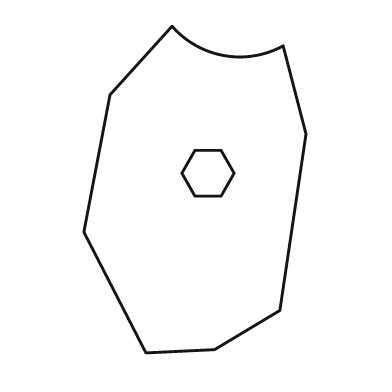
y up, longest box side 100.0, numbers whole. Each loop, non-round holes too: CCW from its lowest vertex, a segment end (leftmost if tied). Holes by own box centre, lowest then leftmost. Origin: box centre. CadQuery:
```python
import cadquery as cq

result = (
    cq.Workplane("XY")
    .moveTo(-15.0, -50.0)
    .lineTo(6.0, -49.0)
    .lineTo(26.0, -37.0)
    .lineTo(34.0, 17.0)
    .lineTo(27.0, 44.0)
    .threePointArc((9.0, 41.0), (-7.0, 50.0))
    .lineTo(-26.0, 29.0)
    .lineTo(-34.0, -13.0)
    .close()
    .moveTo(0.0, -2.0)
    .lineTo(8.0, -2.0)
    .lineTo(12.0, 5.0)
    .lineTo(8.0, 12.0)
    .lineTo(0.0, 12.0)
    .lineTo(-4.0, 5.0)
    .close()
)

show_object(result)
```